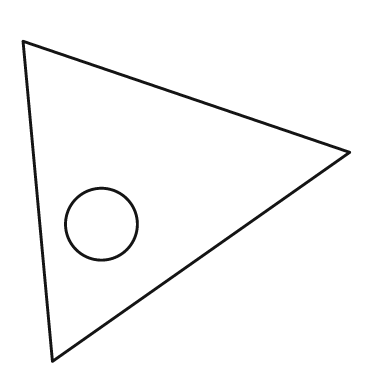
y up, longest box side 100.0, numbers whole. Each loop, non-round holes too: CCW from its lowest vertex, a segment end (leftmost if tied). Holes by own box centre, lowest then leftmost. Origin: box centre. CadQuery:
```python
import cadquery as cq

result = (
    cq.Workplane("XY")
    .moveTo(-41.0, -49.0)
    .lineTo(50.0, 15.0)
    .lineTo(-50.0, 49.0)
    .close()
    .moveTo(-26.0, -7.0)
    .circle(11.0)
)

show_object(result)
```